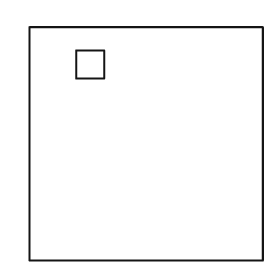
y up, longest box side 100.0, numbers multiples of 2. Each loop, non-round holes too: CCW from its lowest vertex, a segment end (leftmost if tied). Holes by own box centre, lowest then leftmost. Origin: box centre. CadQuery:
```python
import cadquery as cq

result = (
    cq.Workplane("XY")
    .moveTo(-50.0, -50.0)
    .lineTo(50.0, -50.0)
    .lineTo(50.0, 50.0)
    .lineTo(-50.0, 50.0)
    .close()
    .moveTo(-30.0, 28.0)
    .lineTo(-18.0, 28.0)
    .lineTo(-18.0, 40.0)
    .lineTo(-30.0, 40.0)
    .close()
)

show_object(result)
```